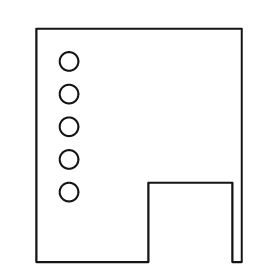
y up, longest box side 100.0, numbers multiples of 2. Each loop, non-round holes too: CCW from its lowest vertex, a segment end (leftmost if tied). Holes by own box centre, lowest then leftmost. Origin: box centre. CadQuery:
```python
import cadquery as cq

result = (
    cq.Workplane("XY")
    .moveTo(-44.0, -50.0)
    .lineTo(4.0, -50.0)
    .lineTo(4.0, -16.0)
    .lineTo(40.0, -16.0)
    .lineTo(40.0, -50.0)
    .lineTo(44.0, -50.0)
    .lineTo(44.0, 50.0)
    .lineTo(-44.0, 50.0)
    .close()
    .moveTo(-30.0, -20.0)
    .circle(4.0)
    .moveTo(-30.0, -6.0)
    .circle(4.0)
    .moveTo(-30.0, 8.0)
    .circle(4.0)
    .moveTo(-30.0, 22.0)
    .circle(4.0)
    .moveTo(-30.0, 36.0)
    .circle(4.0)
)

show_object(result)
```